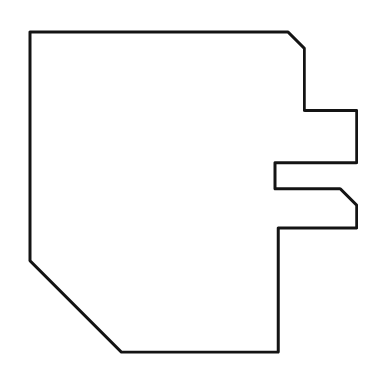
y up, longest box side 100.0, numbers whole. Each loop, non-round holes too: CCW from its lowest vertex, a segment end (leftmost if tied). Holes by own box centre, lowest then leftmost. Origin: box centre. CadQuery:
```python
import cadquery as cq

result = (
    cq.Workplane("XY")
    .moveTo(-22.0, -49.0)
    .lineTo(26.0, -49.0)
    .lineTo(26.0, -11.0)
    .lineTo(50.0, -11.0)
    .lineTo(50.0, -4.0)
    .lineTo(45.0, 1.0)
    .lineTo(25.0, 1.0)
    .lineTo(25.0, 9.0)
    .lineTo(50.0, 9.0)
    .lineTo(50.0, 25.0)
    .lineTo(34.0, 25.0)
    .lineTo(34.0, 44.0)
    .lineTo(29.0, 49.0)
    .lineTo(-50.0, 49.0)
    .lineTo(-50.0, -21.0)
    .close()
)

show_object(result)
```